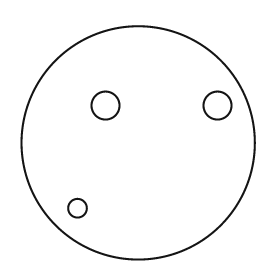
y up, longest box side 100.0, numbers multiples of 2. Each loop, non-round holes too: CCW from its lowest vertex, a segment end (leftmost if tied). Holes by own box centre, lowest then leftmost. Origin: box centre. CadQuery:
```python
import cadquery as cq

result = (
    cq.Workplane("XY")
    .moveTo(0.0, 0.0)
    .circle(50.0)
    .moveTo(-26.0, -28.0)
    .circle(4.0)
    .moveTo(-14.0, 16.0)
    .circle(6.0)
    .moveTo(34.0, 16.0)
    .circle(6.0)
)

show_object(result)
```